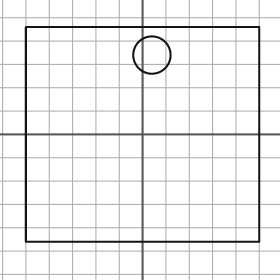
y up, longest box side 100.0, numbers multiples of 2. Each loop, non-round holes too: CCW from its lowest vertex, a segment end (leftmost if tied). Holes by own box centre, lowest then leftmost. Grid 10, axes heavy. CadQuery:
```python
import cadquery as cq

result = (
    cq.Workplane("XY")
    .moveTo(-50.0, -46.0)
    .lineTo(50.0, -46.0)
    .lineTo(50.0, 46.0)
    .lineTo(-50.0, 46.0)
    .close()
    .moveTo(4.0, 34.0)
    .circle(8.0)
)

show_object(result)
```